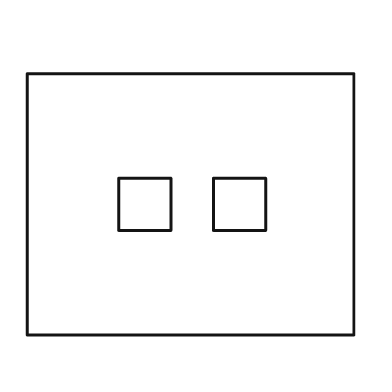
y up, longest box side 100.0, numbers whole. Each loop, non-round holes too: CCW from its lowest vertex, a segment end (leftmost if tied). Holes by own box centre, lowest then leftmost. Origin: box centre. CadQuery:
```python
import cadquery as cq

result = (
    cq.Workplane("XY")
    .moveTo(-50.0, -40.0)
    .lineTo(50.0, -40.0)
    .lineTo(50.0, 40.0)
    .lineTo(-50.0, 40.0)
    .close()
    .moveTo(-22.0, -8.0)
    .lineTo(-6.0, -8.0)
    .lineTo(-6.0, 8.0)
    .lineTo(-22.0, 8.0)
    .close()
    .moveTo(7.0, -8.0)
    .lineTo(23.0, -8.0)
    .lineTo(23.0, 8.0)
    .lineTo(7.0, 8.0)
    .close()
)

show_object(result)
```